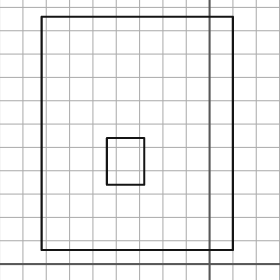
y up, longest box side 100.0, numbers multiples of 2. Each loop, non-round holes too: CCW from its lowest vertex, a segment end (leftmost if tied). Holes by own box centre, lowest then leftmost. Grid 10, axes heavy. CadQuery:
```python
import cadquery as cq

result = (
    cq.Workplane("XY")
    .moveTo(-72.0, 6.0)
    .lineTo(10.0, 6.0)
    .lineTo(10.0, 106.0)
    .lineTo(-72.0, 106.0)
    .close()
    .moveTo(-44.0, 34.0)
    .lineTo(-28.0, 34.0)
    .lineTo(-28.0, 54.0)
    .lineTo(-44.0, 54.0)
    .close()
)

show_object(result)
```